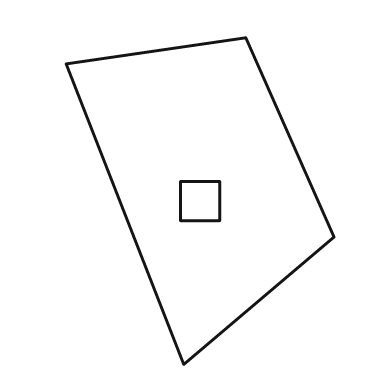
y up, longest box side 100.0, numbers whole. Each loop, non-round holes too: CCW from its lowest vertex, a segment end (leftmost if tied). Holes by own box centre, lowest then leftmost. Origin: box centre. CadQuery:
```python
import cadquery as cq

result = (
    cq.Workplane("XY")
    .moveTo(-5.0, -50.0)
    .lineTo(41.0, -11.0)
    .lineTo(14.0, 50.0)
    .lineTo(-41.0, 42.0)
    .close()
    .moveTo(-6.0, -6.0)
    .lineTo(6.0, -6.0)
    .lineTo(6.0, 6.0)
    .lineTo(-6.0, 6.0)
    .close()
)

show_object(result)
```